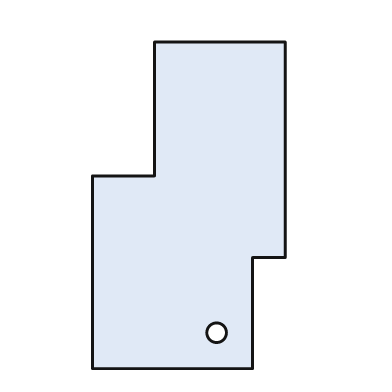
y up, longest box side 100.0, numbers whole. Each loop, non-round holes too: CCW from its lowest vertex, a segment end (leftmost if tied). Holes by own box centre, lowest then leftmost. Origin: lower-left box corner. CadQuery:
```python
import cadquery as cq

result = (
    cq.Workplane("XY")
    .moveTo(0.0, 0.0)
    .lineTo(49.0, 0.0)
    .lineTo(49.0, 34.0)
    .lineTo(59.0, 34.0)
    .lineTo(59.0, 100.0)
    .lineTo(19.0, 100.0)
    .lineTo(19.0, 59.0)
    .lineTo(0.0, 59.0)
    .close()
    .moveTo(38.0, 11.0)
    .circle(3.0)
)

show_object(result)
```